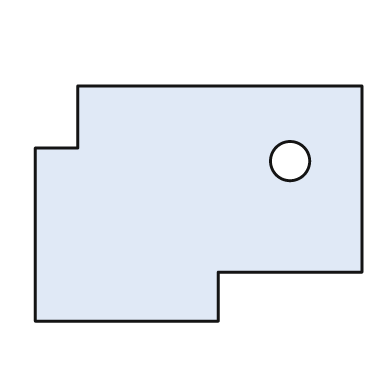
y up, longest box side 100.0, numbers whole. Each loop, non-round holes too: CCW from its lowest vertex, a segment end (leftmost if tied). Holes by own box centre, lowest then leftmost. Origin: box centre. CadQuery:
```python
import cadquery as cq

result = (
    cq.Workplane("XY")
    .moveTo(-50.0, -36.0)
    .lineTo(6.0, -36.0)
    .lineTo(6.0, -21.0)
    .lineTo(50.0, -21.0)
    .lineTo(50.0, 36.0)
    .lineTo(-37.0, 36.0)
    .lineTo(-37.0, 17.0)
    .lineTo(-50.0, 17.0)
    .close()
    .moveTo(28.0, 13.0)
    .circle(6.0)
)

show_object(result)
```